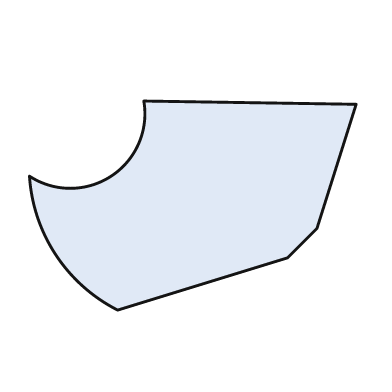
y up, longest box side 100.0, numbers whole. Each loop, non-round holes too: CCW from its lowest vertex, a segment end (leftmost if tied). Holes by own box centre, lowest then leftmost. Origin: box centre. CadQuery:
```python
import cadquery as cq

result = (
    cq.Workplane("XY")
    .moveTo(-23.0, -32.0)
    .lineTo(29.0, -16.0)
    .lineTo(38.0, -7.0)
    .lineTo(50.0, 31.0)
    .lineTo(-15.0, 32.0)
    .threePointArc((-25.0, 9.0), (-50.0, 9.0))
    .threePointArc((-42.0, -15.0), (-23.0, -32.0))
    .close()
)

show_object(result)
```